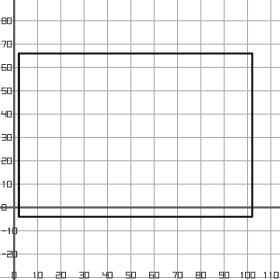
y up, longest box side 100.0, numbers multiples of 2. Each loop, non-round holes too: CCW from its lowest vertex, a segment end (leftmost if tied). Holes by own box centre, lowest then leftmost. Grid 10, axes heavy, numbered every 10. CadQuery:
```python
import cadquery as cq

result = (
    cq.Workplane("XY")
    .moveTo(2.0, -4.0)
    .lineTo(102.0, -4.0)
    .lineTo(102.0, 66.0)
    .lineTo(2.0, 66.0)
    .close()
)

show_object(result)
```